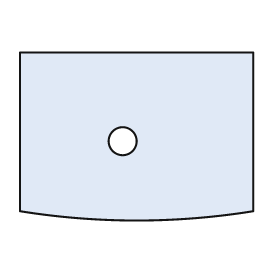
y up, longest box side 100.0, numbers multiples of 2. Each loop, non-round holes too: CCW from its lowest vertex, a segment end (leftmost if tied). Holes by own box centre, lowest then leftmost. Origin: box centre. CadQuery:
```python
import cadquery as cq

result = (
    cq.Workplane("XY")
    .moveTo(-50.0, -32.0)
    .threePointArc((0.0, -36.0), (50.0, -32.0))
    .lineTo(50.0, 36.0)
    .lineTo(-50.0, 36.0)
    .close()
    .moveTo(-6.0, -2.0)
    .circle(6.0)
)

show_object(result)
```